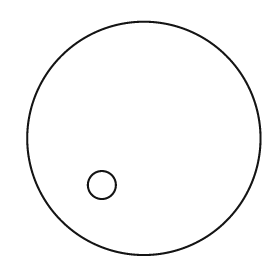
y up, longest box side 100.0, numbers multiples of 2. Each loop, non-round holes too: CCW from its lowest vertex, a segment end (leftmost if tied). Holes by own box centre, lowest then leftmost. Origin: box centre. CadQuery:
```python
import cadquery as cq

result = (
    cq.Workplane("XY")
    .moveTo(0.0, 0.0)
    .circle(50.0)
    .moveTo(-18.0, -20.0)
    .circle(6.0)
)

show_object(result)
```